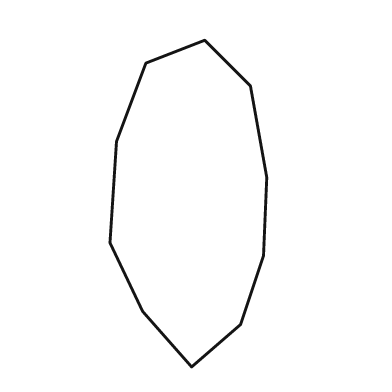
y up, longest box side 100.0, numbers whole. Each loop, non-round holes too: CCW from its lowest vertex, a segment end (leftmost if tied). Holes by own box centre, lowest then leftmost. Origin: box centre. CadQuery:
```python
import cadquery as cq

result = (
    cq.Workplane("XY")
    .moveTo(1.0, -50.0)
    .lineTo(16.0, -37.0)
    .lineTo(23.0, -16.0)
    .lineTo(24.0, 8.0)
    .lineTo(19.0, 36.0)
    .lineTo(5.0, 50.0)
    .lineTo(-13.0, 43.0)
    .lineTo(-22.0, 19.0)
    .lineTo(-24.0, -12.0)
    .lineTo(-14.0, -33.0)
    .close()
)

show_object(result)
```